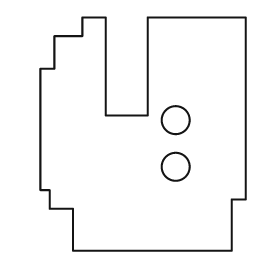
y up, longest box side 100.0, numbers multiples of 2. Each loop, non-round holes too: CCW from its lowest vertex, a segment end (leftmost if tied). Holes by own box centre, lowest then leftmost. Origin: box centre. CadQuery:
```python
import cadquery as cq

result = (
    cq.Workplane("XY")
    .moveTo(-30.0, -50.0)
    .lineTo(38.0, -50.0)
    .lineTo(38.0, -28.0)
    .lineTo(44.0, -28.0)
    .lineTo(44.0, 50.0)
    .lineTo(2.0, 50.0)
    .lineTo(2.0, 8.0)
    .lineTo(-16.0, 8.0)
    .lineTo(-16.0, 50.0)
    .lineTo(-26.0, 50.0)
    .lineTo(-26.0, 42.0)
    .lineTo(-38.0, 42.0)
    .lineTo(-38.0, 28.0)
    .lineTo(-44.0, 28.0)
    .lineTo(-44.0, -24.0)
    .lineTo(-40.0, -24.0)
    .lineTo(-40.0, -32.0)
    .lineTo(-30.0, -32.0)
    .close()
    .moveTo(14.0, -14.0)
    .circle(6.0)
    .moveTo(14.0, 6.0)
    .circle(6.0)
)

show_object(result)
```